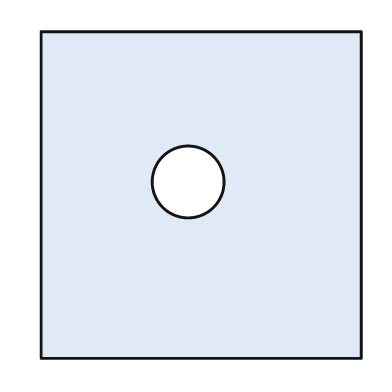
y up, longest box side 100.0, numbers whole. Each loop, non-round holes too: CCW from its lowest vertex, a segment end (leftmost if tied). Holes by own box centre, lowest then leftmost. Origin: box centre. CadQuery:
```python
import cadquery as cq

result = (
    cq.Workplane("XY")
    .moveTo(-49.0, -50.0)
    .lineTo(49.0, -50.0)
    .lineTo(49.0, 50.0)
    .lineTo(-49.0, 50.0)
    .close()
    .moveTo(-4.0, 4.0)
    .circle(11.0)
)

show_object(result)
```